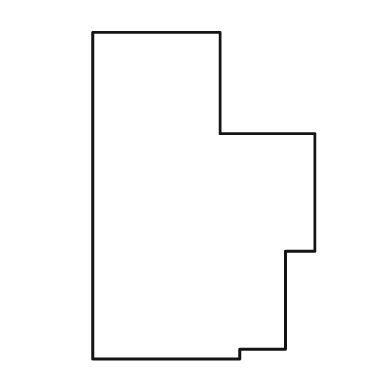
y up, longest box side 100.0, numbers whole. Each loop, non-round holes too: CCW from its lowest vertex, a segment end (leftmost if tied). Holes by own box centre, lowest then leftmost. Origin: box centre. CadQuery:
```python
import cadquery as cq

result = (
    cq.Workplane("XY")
    .moveTo(-34.0, -50.0)
    .lineTo(11.0, -50.0)
    .lineTo(11.0, -47.0)
    .lineTo(25.0, -47.0)
    .lineTo(25.0, -17.0)
    .lineTo(34.0, -17.0)
    .lineTo(34.0, 19.0)
    .lineTo(5.0, 19.0)
    .lineTo(5.0, 50.0)
    .lineTo(-34.0, 50.0)
    .close()
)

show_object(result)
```